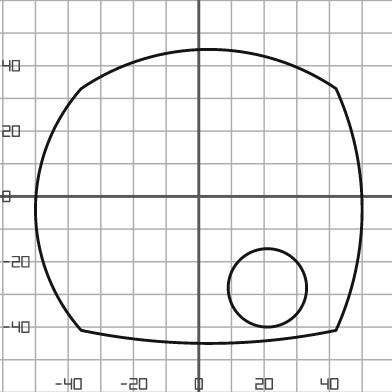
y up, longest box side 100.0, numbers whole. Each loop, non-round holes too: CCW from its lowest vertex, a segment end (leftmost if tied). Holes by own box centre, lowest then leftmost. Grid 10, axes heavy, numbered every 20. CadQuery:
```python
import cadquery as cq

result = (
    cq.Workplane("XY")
    .moveTo(-36.0, -41.0)
    .threePointArc((3.0, -45.0), (42.0, -41.0))
    .threePointArc((50.0, -4.0), (42.0, 33.0))
    .threePointArc((3.0, 45.0), (-36.0, 33.0))
    .threePointArc((-50.0, -4.0), (-36.0, -41.0))
    .close()
    .moveTo(21.0, -28.0)
    .circle(12.0)
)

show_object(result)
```